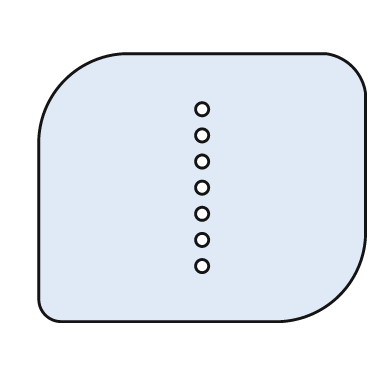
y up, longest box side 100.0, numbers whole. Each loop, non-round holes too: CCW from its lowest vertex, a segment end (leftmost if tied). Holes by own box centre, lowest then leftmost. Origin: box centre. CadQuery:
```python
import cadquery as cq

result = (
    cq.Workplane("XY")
    .moveTo(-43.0, -41.0)
    .lineTo(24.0, -41.0)
    .threePointArc((42.0, -33.0), (50.0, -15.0))
    .lineTo(50.0, 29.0)
    .threePointArc((46.0, 37.0), (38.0, 41.0))
    .lineTo(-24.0, 41.0)
    .threePointArc((-42.0, 33.0), (-50.0, 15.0))
    .lineTo(-50.0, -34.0)
    .threePointArc((-48.0, -39.0), (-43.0, -41.0))
    .close()
    .moveTo(0.0, -24.0)
    .circle(2.0)
    .moveTo(0.0, -16.0)
    .circle(2.0)
    .moveTo(0.0, -8.0)
    .circle(2.0)
    .moveTo(0.0, 0.0)
    .circle(2.0)
    .moveTo(0.0, 8.0)
    .circle(2.0)
    .moveTo(0.0, 16.0)
    .circle(2.0)
    .moveTo(0.0, 24.0)
    .circle(2.0)
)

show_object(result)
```